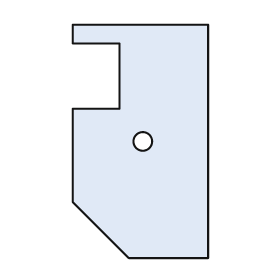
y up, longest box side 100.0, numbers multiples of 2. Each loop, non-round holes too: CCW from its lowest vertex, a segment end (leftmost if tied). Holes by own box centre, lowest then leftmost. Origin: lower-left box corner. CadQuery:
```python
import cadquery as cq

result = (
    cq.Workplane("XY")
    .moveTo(24.0, 0.0)
    .lineTo(58.0, 0.0)
    .lineTo(58.0, 100.0)
    .lineTo(0.0, 100.0)
    .lineTo(0.0, 92.0)
    .lineTo(20.0, 92.0)
    .lineTo(20.0, 64.0)
    .lineTo(0.0, 64.0)
    .lineTo(0.0, 24.0)
    .close()
    .moveTo(30.0, 50.0)
    .circle(4.0)
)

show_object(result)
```